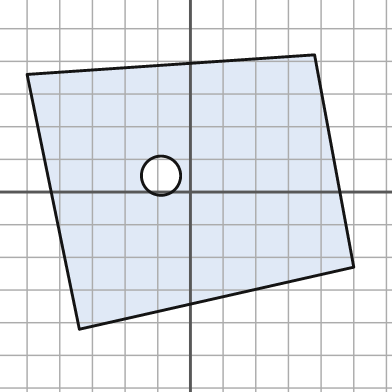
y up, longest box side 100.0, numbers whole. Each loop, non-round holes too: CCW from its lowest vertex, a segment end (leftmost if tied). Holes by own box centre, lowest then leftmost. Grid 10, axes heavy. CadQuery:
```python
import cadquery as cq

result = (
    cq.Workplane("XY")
    .moveTo(-34.0, -42.0)
    .lineTo(50.0, -23.0)
    .lineTo(38.0, 42.0)
    .lineTo(-50.0, 36.0)
    .close()
    .moveTo(-9.0, 5.0)
    .circle(6.0)
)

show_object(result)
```